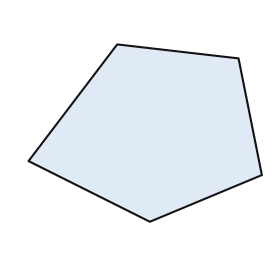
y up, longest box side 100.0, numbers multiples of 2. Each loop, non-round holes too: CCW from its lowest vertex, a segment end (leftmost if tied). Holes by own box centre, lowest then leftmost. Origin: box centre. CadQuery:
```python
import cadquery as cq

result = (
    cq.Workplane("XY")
    .moveTo(2.0, -38.0)
    .lineTo(50.0, -18.0)
    .lineTo(40.0, 32.0)
    .lineTo(-12.0, 38.0)
    .lineTo(-50.0, -12.0)
    .close()
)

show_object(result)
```